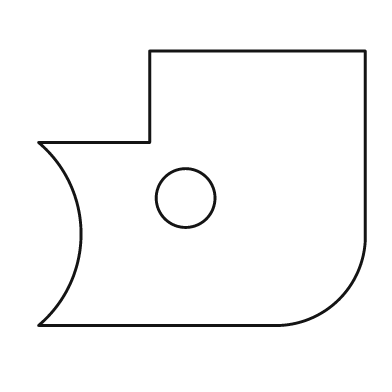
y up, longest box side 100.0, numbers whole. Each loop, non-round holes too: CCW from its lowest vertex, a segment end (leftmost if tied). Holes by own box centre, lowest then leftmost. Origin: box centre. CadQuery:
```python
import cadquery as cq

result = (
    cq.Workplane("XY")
    .moveTo(-50.0, -42.0)
    .lineTo(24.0, -42.0)
    .threePointArc((42.0, -34.0), (50.0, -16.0))
    .lineTo(50.0, 42.0)
    .lineTo(-16.0, 42.0)
    .lineTo(-16.0, 14.0)
    .lineTo(-50.0, 14.0)
    .threePointArc((-37.0, -14.0), (-50.0, -42.0))
    .close()
    .moveTo(-5.0, -3.0)
    .circle(9.0)
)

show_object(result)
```